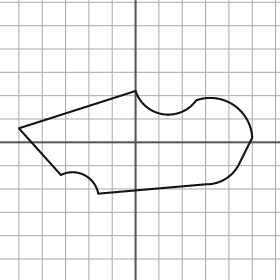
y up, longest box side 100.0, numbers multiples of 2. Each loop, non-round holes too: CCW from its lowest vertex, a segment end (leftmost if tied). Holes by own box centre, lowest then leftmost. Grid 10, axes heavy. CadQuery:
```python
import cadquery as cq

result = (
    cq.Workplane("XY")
    .moveTo(-16.0, -22.0)
    .lineTo(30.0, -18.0)
    .threePointArc((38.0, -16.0), (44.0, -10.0))
    .lineTo(50.0, 2.0)
    .threePointArc((42.0, 16.0), (26.0, 18.0))
    .threePointArc((12.0, 12.0), (0.0, 22.0))
    .lineTo(-50.0, 6.0)
    .lineTo(-32.0, -14.0)
    .threePointArc((-22.0, -14.0), (-16.0, -22.0))
    .close()
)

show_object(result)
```